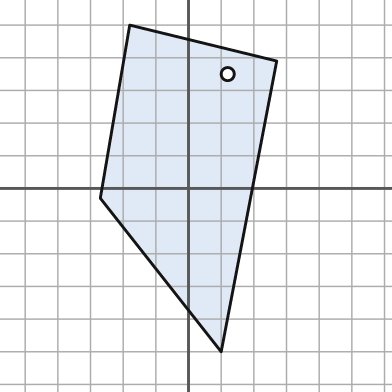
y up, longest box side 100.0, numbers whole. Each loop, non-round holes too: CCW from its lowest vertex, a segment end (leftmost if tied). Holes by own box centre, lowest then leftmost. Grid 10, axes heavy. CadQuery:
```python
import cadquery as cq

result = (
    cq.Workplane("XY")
    .moveTo(10.0, -50.0)
    .lineTo(27.0, 39.0)
    .lineTo(-18.0, 50.0)
    .lineTo(-27.0, -3.0)
    .close()
    .moveTo(12.0, 35.0)
    .circle(2.0)
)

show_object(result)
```